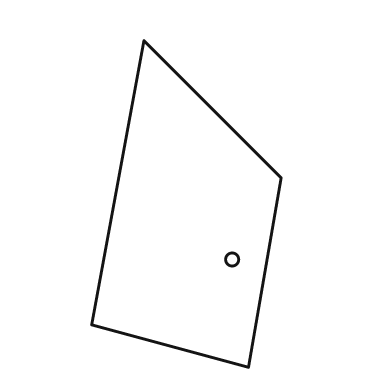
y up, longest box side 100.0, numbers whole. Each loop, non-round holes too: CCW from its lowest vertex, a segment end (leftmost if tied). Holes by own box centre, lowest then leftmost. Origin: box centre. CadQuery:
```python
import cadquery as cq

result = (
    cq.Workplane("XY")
    .moveTo(19.0, -50.0)
    .lineTo(29.0, 8.0)
    .lineTo(-13.0, 50.0)
    .lineTo(-29.0, -37.0)
    .close()
    .moveTo(14.0, -17.0)
    .circle(2.0)
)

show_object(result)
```